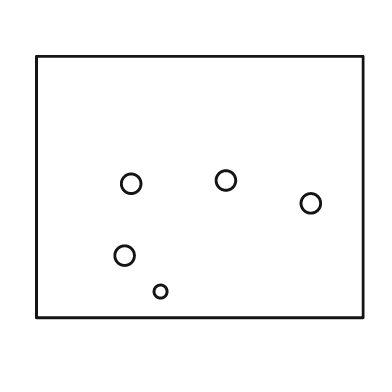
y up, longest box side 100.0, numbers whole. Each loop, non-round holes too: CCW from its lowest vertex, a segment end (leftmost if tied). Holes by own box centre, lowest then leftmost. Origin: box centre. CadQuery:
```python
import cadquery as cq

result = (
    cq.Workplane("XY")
    .moveTo(-50.0, -40.0)
    .lineTo(50.0, -40.0)
    .lineTo(50.0, 40.0)
    .lineTo(-50.0, 40.0)
    .close()
    .moveTo(-12.0, -32.0)
    .circle(2.0)
    .moveTo(-23.0, -21.0)
    .circle(3.0)
    .moveTo(34.0, -5.0)
    .circle(3.0)
    .moveTo(-21.0, 1.0)
    .circle(3.0)
    .moveTo(8.0, 2.0)
    .circle(3.0)
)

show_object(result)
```